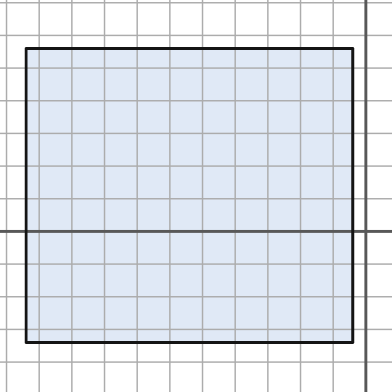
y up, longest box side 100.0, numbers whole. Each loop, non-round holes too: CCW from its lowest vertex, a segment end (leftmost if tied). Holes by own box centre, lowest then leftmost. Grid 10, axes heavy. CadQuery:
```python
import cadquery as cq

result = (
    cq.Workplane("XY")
    .moveTo(-104.0, -34.0)
    .lineTo(-4.0, -34.0)
    .lineTo(-4.0, 56.0)
    .lineTo(-104.0, 56.0)
    .close()
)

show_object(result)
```